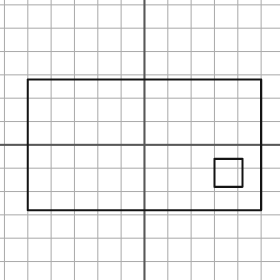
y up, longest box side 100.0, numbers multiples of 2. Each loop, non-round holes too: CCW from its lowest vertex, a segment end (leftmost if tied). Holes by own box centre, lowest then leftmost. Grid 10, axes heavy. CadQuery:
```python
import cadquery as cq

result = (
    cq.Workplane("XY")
    .moveTo(-50.0, -28.0)
    .lineTo(50.0, -28.0)
    .lineTo(50.0, 28.0)
    .lineTo(-50.0, 28.0)
    .close()
    .moveTo(30.0, -18.0)
    .lineTo(42.0, -18.0)
    .lineTo(42.0, -6.0)
    .lineTo(30.0, -6.0)
    .close()
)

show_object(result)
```